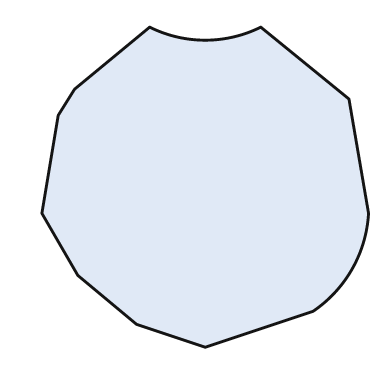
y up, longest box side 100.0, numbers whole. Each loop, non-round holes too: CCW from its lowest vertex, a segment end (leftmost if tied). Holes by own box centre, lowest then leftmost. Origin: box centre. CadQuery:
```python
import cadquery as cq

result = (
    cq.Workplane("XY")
    .moveTo(0.0, -49.0)
    .lineTo(33.0, -38.0)
    .threePointArc((45.0, -25.0), (50.0, -8.0))
    .lineTo(44.0, 27.0)
    .lineTo(17.0, 49.0)
    .threePointArc((0.0, 45.0), (-17.0, 49.0))
    .lineTo(-40.0, 30.0)
    .lineTo(-45.0, 22.0)
    .lineTo(-50.0, -8.0)
    .lineTo(-39.0, -27.0)
    .lineTo(-21.0, -42.0)
    .close()
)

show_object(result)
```